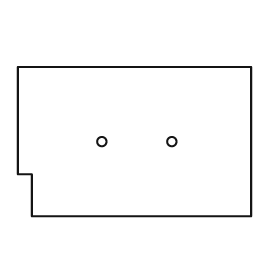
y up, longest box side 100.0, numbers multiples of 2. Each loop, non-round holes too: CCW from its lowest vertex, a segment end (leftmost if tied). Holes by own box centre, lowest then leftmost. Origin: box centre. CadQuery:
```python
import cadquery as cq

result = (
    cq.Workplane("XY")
    .moveTo(-44.0, -32.0)
    .lineTo(50.0, -32.0)
    .lineTo(50.0, 32.0)
    .lineTo(-50.0, 32.0)
    .lineTo(-50.0, -14.0)
    .lineTo(-44.0, -14.0)
    .close()
    .moveTo(-14.0, 0.0)
    .circle(2.0)
    .moveTo(16.0, 0.0)
    .circle(2.0)
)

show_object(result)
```